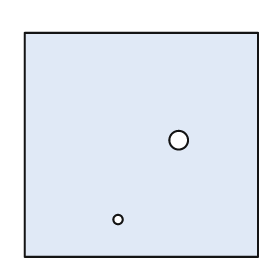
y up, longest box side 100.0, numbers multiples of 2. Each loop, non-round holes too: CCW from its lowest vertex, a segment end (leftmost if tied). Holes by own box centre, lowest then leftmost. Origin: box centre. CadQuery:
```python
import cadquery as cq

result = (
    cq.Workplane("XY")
    .moveTo(-50.0, -48.0)
    .lineTo(50.0, -48.0)
    .lineTo(50.0, 48.0)
    .lineTo(-50.0, 48.0)
    .close()
    .moveTo(-10.0, -32.0)
    .circle(2.0)
    .moveTo(16.0, 2.0)
    .circle(4.0)
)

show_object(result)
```